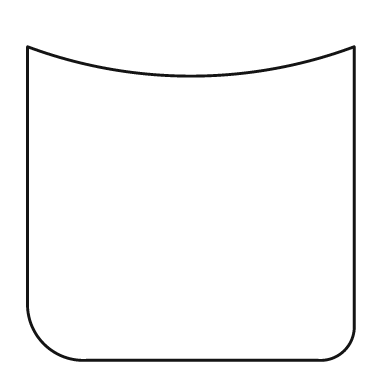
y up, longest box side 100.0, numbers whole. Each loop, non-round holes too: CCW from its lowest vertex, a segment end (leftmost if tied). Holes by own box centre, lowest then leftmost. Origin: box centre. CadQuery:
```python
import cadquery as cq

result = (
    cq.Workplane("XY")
    .moveTo(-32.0, -48.0)
    .lineTo(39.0, -48.0)
    .threePointArc((47.0, -45.0), (50.0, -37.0))
    .lineTo(50.0, 48.0)
    .threePointArc((0.0, 39.0), (-50.0, 48.0))
    .lineTo(-50.0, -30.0)
    .threePointArc((-45.0, -43.0), (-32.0, -48.0))
    .close()
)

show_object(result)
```